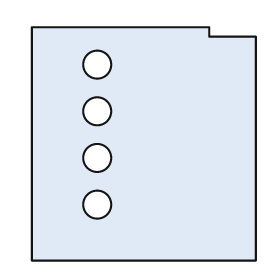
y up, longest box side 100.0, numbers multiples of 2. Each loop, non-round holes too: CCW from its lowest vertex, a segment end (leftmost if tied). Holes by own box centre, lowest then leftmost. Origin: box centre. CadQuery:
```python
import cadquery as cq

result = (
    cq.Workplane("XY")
    .moveTo(-48.0, -50.0)
    .lineTo(48.0, -50.0)
    .lineTo(48.0, 46.0)
    .lineTo(28.0, 46.0)
    .lineTo(28.0, 50.0)
    .lineTo(-48.0, 50.0)
    .close()
    .moveTo(-20.0, -26.0)
    .circle(6.0)
    .moveTo(-20.0, -6.0)
    .circle(6.0)
    .moveTo(-20.0, 14.0)
    .circle(6.0)
    .moveTo(-20.0, 34.0)
    .circle(6.0)
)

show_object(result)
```